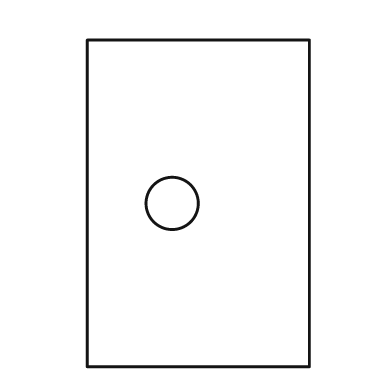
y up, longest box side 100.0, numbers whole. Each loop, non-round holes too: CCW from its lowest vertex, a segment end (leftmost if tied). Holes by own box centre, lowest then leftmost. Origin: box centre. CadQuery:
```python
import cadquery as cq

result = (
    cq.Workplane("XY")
    .moveTo(-34.0, -50.0)
    .lineTo(34.0, -50.0)
    .lineTo(34.0, 50.0)
    .lineTo(-34.0, 50.0)
    .close()
    .moveTo(-8.0, 0.0)
    .circle(8.0)
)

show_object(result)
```